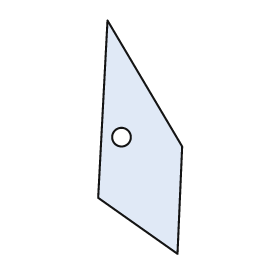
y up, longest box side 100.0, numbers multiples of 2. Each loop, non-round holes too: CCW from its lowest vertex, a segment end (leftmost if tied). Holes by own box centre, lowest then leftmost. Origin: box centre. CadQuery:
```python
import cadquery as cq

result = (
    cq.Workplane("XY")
    .moveTo(16.0, -50.0)
    .lineTo(18.0, -4.0)
    .lineTo(-14.0, 50.0)
    .lineTo(-18.0, -26.0)
    .close()
    .moveTo(-8.0, 0.0)
    .circle(4.0)
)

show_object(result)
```